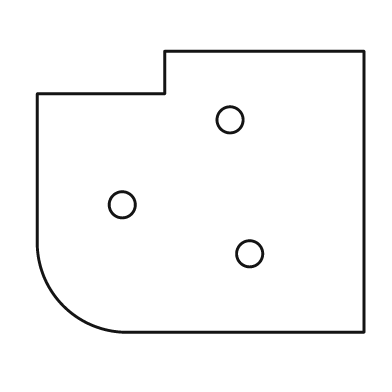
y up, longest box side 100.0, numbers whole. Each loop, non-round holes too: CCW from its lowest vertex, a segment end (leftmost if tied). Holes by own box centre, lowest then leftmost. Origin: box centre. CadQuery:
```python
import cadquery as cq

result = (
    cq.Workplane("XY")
    .moveTo(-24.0, -43.0)
    .lineTo(50.0, -43.0)
    .lineTo(50.0, 43.0)
    .lineTo(-11.0, 43.0)
    .lineTo(-11.0, 30.0)
    .lineTo(-50.0, 30.0)
    .lineTo(-50.0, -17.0)
    .threePointArc((-42.0, -35.0), (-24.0, -43.0))
    .close()
    .moveTo(15.0, -19.0)
    .circle(4.0)
    .moveTo(-24.0, -4.0)
    .circle(4.0)
    .moveTo(9.0, 22.0)
    .circle(4.0)
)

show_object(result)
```